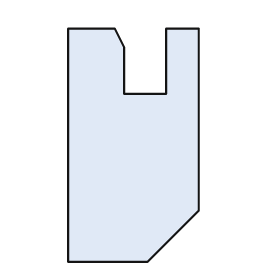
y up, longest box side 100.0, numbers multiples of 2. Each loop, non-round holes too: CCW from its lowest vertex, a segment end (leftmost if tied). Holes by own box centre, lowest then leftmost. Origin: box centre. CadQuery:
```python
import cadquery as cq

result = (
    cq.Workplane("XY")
    .moveTo(-28.0, -50.0)
    .lineTo(6.0, -50.0)
    .lineTo(28.0, -28.0)
    .lineTo(28.0, 50.0)
    .lineTo(14.0, 50.0)
    .lineTo(14.0, 22.0)
    .lineTo(-4.0, 22.0)
    .lineTo(-4.0, 42.0)
    .lineTo(-8.0, 50.0)
    .lineTo(-28.0, 50.0)
    .close()
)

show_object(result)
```